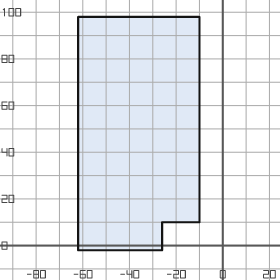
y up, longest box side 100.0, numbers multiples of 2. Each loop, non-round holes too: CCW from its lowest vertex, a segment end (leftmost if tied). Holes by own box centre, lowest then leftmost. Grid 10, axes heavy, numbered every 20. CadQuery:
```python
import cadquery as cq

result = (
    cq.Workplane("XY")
    .moveTo(-62.0, -2.0)
    .lineTo(-26.0, -2.0)
    .lineTo(-26.0, 10.0)
    .lineTo(-10.0, 10.0)
    .lineTo(-10.0, 98.0)
    .lineTo(-62.0, 98.0)
    .close()
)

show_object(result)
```